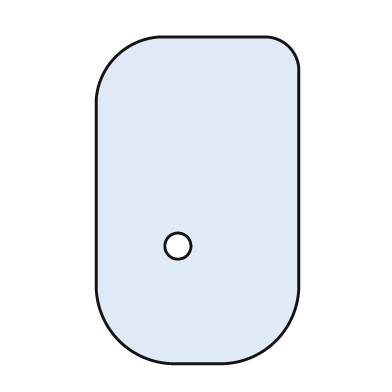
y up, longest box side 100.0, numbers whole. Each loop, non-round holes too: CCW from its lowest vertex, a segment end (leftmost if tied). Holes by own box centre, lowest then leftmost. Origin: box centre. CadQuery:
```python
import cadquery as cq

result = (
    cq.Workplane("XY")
    .moveTo(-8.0, -50.0)
    .lineTo(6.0, -50.0)
    .threePointArc((24.0, -43.0), (31.0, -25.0))
    .lineTo(31.0, 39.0)
    .threePointArc((28.0, 47.0), (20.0, 50.0))
    .lineTo(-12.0, 50.0)
    .threePointArc((-25.0, 44.0), (-31.0, 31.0))
    .lineTo(-31.0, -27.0)
    .threePointArc((-24.0, -43.0), (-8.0, -50.0))
    .close()
    .moveTo(-6.0, -14.0)
    .circle(4.0)
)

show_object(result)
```